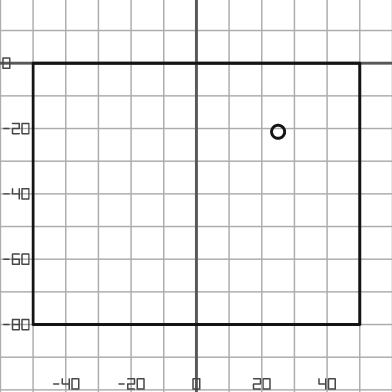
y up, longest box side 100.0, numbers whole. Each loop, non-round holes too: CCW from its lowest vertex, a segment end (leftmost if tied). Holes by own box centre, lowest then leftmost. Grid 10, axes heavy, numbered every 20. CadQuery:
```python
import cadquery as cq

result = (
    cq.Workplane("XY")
    .moveTo(-50.0, -80.0)
    .lineTo(50.0, -80.0)
    .lineTo(50.0, 0.0)
    .lineTo(-50.0, 0.0)
    .close()
    .moveTo(25.0, -21.0)
    .circle(2.0)
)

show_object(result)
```